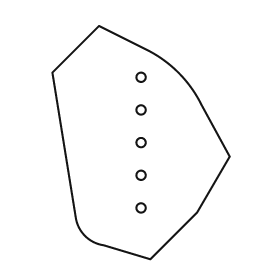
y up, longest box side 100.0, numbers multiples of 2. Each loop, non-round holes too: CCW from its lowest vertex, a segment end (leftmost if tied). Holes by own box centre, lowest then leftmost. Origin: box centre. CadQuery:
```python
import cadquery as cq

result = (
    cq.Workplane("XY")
    .moveTo(4.0, -50.0)
    .lineTo(24.0, -30.0)
    .lineTo(38.0, -6.0)
    .lineTo(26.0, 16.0)
    .threePointArc((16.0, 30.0), (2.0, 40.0))
    .lineTo(-18.0, 50.0)
    .lineTo(-38.0, 30.0)
    .lineTo(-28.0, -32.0)
    .threePointArc((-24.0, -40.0), (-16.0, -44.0))
    .close()
    .moveTo(0.0, -28.0)
    .circle(2.0)
    .moveTo(0.0, -14.0)
    .circle(2.0)
    .moveTo(0.0, 0.0)
    .circle(2.0)
    .moveTo(0.0, 14.0)
    .circle(2.0)
    .moveTo(0.0, 28.0)
    .circle(2.0)
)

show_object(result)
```